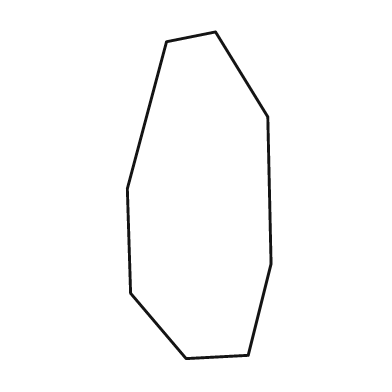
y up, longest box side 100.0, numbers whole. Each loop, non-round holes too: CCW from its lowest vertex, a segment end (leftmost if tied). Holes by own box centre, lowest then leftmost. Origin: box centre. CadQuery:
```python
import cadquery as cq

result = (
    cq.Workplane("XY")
    .moveTo(-4.0, -50.0)
    .lineTo(15.0, -49.0)
    .lineTo(22.0, -21.0)
    .lineTo(21.0, 24.0)
    .lineTo(5.0, 50.0)
    .lineTo(-10.0, 47.0)
    .lineTo(-22.0, 2.0)
    .lineTo(-21.0, -30.0)
    .close()
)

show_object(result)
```